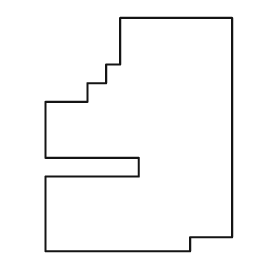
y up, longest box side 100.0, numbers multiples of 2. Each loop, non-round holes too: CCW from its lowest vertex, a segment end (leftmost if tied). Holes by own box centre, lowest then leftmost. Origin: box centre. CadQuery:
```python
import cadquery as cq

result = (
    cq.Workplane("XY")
    .moveTo(-40.0, -50.0)
    .lineTo(22.0, -50.0)
    .lineTo(22.0, -44.0)
    .lineTo(40.0, -44.0)
    .lineTo(40.0, 50.0)
    .lineTo(-8.0, 50.0)
    .lineTo(-8.0, 30.0)
    .lineTo(-14.0, 30.0)
    .lineTo(-14.0, 22.0)
    .lineTo(-22.0, 22.0)
    .lineTo(-22.0, 14.0)
    .lineTo(-40.0, 14.0)
    .lineTo(-40.0, -10.0)
    .lineTo(0.0, -10.0)
    .lineTo(0.0, -18.0)
    .lineTo(-40.0, -18.0)
    .close()
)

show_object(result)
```